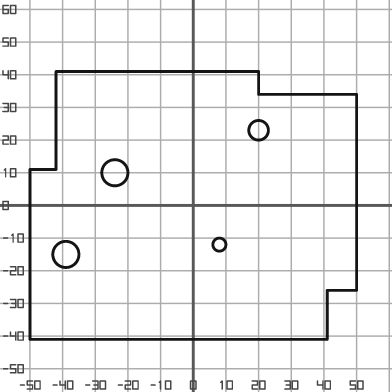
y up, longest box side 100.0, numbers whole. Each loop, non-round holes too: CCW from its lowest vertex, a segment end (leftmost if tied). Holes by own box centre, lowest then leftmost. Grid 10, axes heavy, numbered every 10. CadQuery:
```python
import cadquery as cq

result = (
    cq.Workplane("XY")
    .moveTo(-50.0, -41.0)
    .lineTo(41.0, -41.0)
    .lineTo(41.0, -26.0)
    .lineTo(50.0, -26.0)
    .lineTo(50.0, 34.0)
    .lineTo(20.0, 34.0)
    .lineTo(20.0, 41.0)
    .lineTo(-42.0, 41.0)
    .lineTo(-42.0, 11.0)
    .lineTo(-50.0, 11.0)
    .close()
    .moveTo(-39.0, -15.0)
    .circle(4.0)
    .moveTo(8.0, -12.0)
    .circle(2.0)
    .moveTo(-24.0, 10.0)
    .circle(4.0)
    .moveTo(20.0, 23.0)
    .circle(3.0)
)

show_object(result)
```